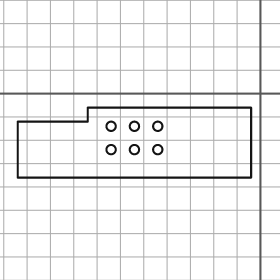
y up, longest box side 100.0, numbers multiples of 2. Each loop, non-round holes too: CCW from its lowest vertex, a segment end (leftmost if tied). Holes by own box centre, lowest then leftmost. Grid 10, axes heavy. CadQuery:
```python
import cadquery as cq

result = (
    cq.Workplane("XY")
    .moveTo(-104.0, -36.0)
    .lineTo(-4.0, -36.0)
    .lineTo(-4.0, -6.0)
    .lineTo(-74.0, -6.0)
    .lineTo(-74.0, -12.0)
    .lineTo(-104.0, -12.0)
    .close()
    .moveTo(-64.0, -24.0)
    .circle(2.0)
    .moveTo(-54.0, -24.0)
    .circle(2.0)
    .moveTo(-44.0, -24.0)
    .circle(2.0)
    .moveTo(-64.0, -14.0)
    .circle(2.0)
    .moveTo(-54.0, -14.0)
    .circle(2.0)
    .moveTo(-44.0, -14.0)
    .circle(2.0)
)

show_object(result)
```